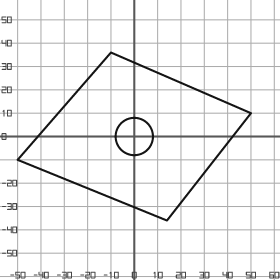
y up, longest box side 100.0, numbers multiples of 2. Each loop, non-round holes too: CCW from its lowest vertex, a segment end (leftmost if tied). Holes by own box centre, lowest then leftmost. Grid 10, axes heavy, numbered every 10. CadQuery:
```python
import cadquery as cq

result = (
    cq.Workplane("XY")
    .moveTo(14.0, -36.0)
    .lineTo(50.0, 10.0)
    .lineTo(-10.0, 36.0)
    .lineTo(-50.0, -10.0)
    .close()
    .moveTo(0.0, 0.0)
    .circle(8.0)
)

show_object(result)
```